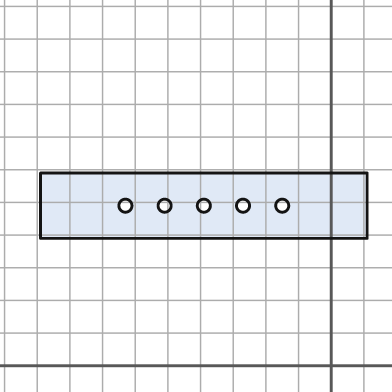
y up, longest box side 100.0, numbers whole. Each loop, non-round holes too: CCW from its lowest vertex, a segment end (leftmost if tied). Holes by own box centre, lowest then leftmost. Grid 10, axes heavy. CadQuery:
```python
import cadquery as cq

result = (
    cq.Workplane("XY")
    .moveTo(-89.0, 39.0)
    .lineTo(11.0, 39.0)
    .lineTo(11.0, 59.0)
    .lineTo(-89.0, 59.0)
    .close()
    .moveTo(-63.0, 49.0)
    .circle(2.0)
    .moveTo(-51.0, 49.0)
    .circle(2.0)
    .moveTo(-39.0, 49.0)
    .circle(2.0)
    .moveTo(-27.0, 49.0)
    .circle(2.0)
    .moveTo(-15.0, 49.0)
    .circle(2.0)
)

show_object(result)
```